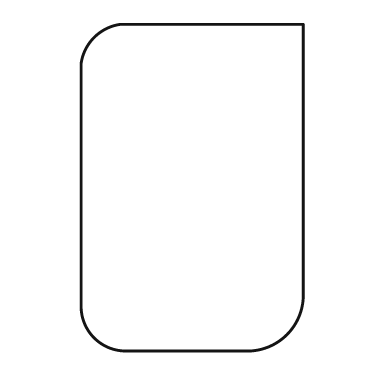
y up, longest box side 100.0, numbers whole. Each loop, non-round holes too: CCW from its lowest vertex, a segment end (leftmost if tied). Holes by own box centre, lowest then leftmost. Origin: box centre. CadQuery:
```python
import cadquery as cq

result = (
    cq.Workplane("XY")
    .moveTo(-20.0, -50.0)
    .lineTo(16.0, -50.0)
    .threePointArc((29.0, -45.0), (34.0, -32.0))
    .lineTo(34.0, 50.0)
    .lineTo(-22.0, 50.0)
    .threePointArc((-30.0, 46.0), (-34.0, 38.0))
    .lineTo(-34.0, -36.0)
    .threePointArc((-30.0, -46.0), (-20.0, -50.0))
    .close()
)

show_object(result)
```